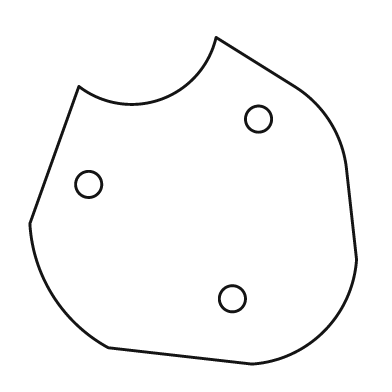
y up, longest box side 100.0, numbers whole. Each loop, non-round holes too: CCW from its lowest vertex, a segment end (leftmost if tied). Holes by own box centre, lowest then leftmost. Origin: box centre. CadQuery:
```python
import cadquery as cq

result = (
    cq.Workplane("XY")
    .moveTo(18.0, -50.0)
    .threePointArc((40.0, -40.0), (50.0, -18.0))
    .lineTo(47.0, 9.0)
    .threePointArc((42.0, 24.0), (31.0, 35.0))
    .lineTo(7.0, 50.0)
    .threePointArc((-10.0, 31.0), (-35.0, 35.0))
    .lineTo(-50.0, -7.0)
    .threePointArc((-43.0, -29.0), (-26.0, -45.0))
    .close()
    .moveTo(12.0, -30.0)
    .circle(4.0)
    .moveTo(-32.0, 5.0)
    .circle(4.0)
    .moveTo(20.0, 25.0)
    .circle(4.0)
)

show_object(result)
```